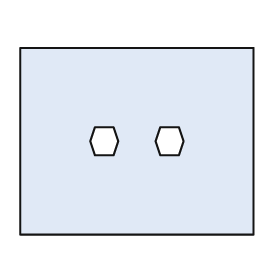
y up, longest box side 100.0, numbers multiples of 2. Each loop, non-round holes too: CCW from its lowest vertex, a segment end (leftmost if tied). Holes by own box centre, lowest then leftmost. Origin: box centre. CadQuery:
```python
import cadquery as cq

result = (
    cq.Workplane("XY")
    .moveTo(-50.0, -40.0)
    .lineTo(50.0, -40.0)
    .lineTo(50.0, 40.0)
    .lineTo(-50.0, 40.0)
    .close()
    .moveTo(-18.0, -6.0)
    .lineTo(-10.0, -6.0)
    .lineTo(-8.0, 0.0)
    .lineTo(-10.0, 6.0)
    .lineTo(-18.0, 6.0)
    .lineTo(-20.0, 0.0)
    .close()
    .moveTo(10.0, -6.0)
    .lineTo(18.0, -6.0)
    .lineTo(20.0, 0.0)
    .lineTo(18.0, 6.0)
    .lineTo(10.0, 6.0)
    .lineTo(8.0, 0.0)
    .close()
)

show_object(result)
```